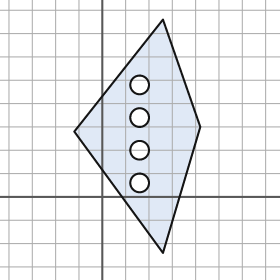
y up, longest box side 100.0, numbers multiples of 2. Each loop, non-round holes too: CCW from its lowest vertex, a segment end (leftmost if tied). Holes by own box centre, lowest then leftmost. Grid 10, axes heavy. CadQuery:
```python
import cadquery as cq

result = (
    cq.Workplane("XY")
    .moveTo(26.0, -24.0)
    .lineTo(42.0, 30.0)
    .lineTo(26.0, 76.0)
    .lineTo(-12.0, 28.0)
    .close()
    .moveTo(16.0, 6.0)
    .circle(4.0)
    .moveTo(16.0, 20.0)
    .circle(4.0)
    .moveTo(16.0, 34.0)
    .circle(4.0)
    .moveTo(16.0, 48.0)
    .circle(4.0)
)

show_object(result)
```